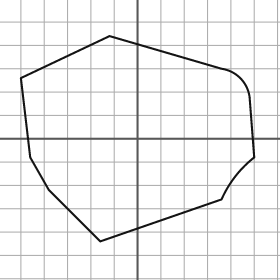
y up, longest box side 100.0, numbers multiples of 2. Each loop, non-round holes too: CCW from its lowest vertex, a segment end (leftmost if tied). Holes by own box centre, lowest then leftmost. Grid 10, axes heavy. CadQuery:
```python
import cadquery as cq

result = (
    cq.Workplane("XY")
    .moveTo(-16.0, -44.0)
    .lineTo(36.0, -26.0)
    .threePointArc((42.0, -16.0), (50.0, -8.0))
    .lineTo(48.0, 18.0)
    .threePointArc((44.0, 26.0), (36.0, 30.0))
    .lineTo(-12.0, 44.0)
    .lineTo(-50.0, 26.0)
    .lineTo(-46.0, -8.0)
    .lineTo(-38.0, -22.0)
    .close()
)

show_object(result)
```